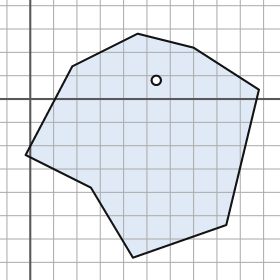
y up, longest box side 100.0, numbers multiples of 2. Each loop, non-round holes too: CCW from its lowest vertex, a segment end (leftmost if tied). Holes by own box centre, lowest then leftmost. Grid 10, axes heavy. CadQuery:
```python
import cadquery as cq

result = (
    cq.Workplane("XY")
    .moveTo(44.0, -68.0)
    .lineTo(84.0, -54.0)
    .lineTo(98.0, 4.0)
    .lineTo(70.0, 22.0)
    .lineTo(46.0, 28.0)
    .lineTo(18.0, 14.0)
    .lineTo(-2.0, -24.0)
    .lineTo(26.0, -38.0)
    .close()
    .moveTo(54.0, 8.0)
    .circle(2.0)
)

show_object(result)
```